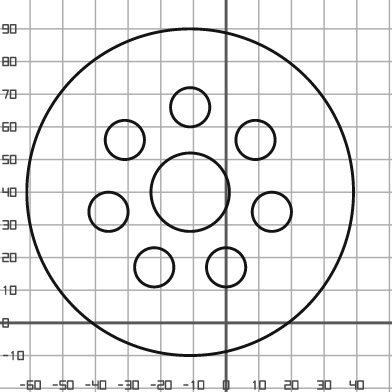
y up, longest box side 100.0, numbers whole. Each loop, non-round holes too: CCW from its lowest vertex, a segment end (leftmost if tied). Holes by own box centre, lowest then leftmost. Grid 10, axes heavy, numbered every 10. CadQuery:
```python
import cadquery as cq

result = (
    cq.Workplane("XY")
    .moveTo(-11.0, 40.0)
    .circle(50.0)
    .moveTo(-22.0, 17.0)
    .circle(6.0)
    .moveTo(0.0, 17.0)
    .circle(6.0)
    .moveTo(-36.0, 34.0)
    .circle(6.0)
    .moveTo(14.0, 34.0)
    .circle(6.0)
    .moveTo(-11.0, 40.0)
    .circle(12.0)
    .moveTo(-31.0, 56.0)
    .circle(6.0)
    .moveTo(9.0, 56.0)
    .circle(6.0)
    .moveTo(-11.0, 66.0)
    .circle(6.0)
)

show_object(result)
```